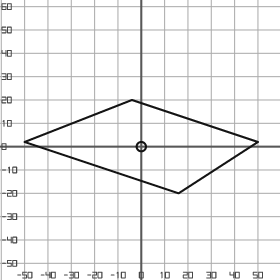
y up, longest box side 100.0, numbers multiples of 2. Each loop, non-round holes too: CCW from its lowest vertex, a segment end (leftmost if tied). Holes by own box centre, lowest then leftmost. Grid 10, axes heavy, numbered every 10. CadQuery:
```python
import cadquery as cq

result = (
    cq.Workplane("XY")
    .moveTo(16.0, -20.0)
    .lineTo(50.0, 2.0)
    .lineTo(-4.0, 20.0)
    .lineTo(-50.0, 2.0)
    .close()
    .moveTo(0.0, 0.0)
    .circle(2.0)
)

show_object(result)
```